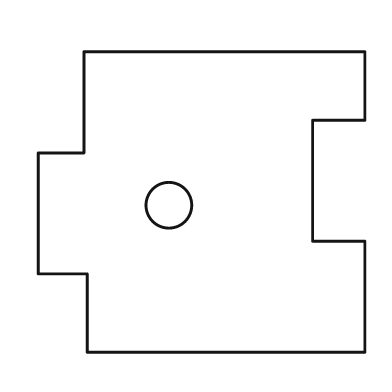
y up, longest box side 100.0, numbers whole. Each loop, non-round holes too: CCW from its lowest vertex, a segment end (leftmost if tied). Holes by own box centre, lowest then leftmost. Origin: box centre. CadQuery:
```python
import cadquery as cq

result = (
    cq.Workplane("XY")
    .moveTo(-35.0, -46.0)
    .lineTo(50.0, -46.0)
    .lineTo(50.0, -12.0)
    .lineTo(34.0, -12.0)
    .lineTo(34.0, 25.0)
    .lineTo(50.0, 25.0)
    .lineTo(50.0, 46.0)
    .lineTo(-36.0, 46.0)
    .lineTo(-36.0, 15.0)
    .lineTo(-50.0, 15.0)
    .lineTo(-50.0, -22.0)
    .lineTo(-35.0, -22.0)
    .close()
    .moveTo(-10.0, -1.0)
    .circle(7.0)
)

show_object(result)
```